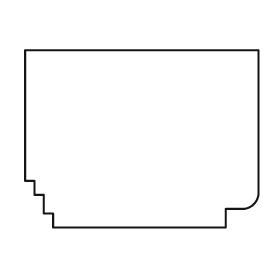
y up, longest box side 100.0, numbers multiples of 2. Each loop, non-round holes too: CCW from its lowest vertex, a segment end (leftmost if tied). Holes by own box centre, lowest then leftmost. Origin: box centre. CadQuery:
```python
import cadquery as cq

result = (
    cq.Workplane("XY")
    .moveTo(-38.0, -38.0)
    .lineTo(36.0, -38.0)
    .lineTo(36.0, -30.0)
    .lineTo(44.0, -30.0)
    .threePointArc((48.0, -28.0), (50.0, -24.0))
    .lineTo(50.0, 38.0)
    .lineTo(-50.0, 38.0)
    .lineTo(-50.0, -18.0)
    .lineTo(-46.0, -18.0)
    .lineTo(-46.0, -24.0)
    .lineTo(-42.0, -24.0)
    .lineTo(-42.0, -32.0)
    .lineTo(-38.0, -32.0)
    .close()
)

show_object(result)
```